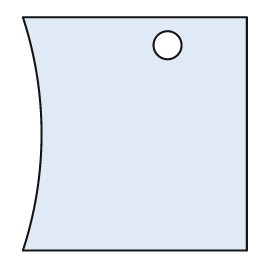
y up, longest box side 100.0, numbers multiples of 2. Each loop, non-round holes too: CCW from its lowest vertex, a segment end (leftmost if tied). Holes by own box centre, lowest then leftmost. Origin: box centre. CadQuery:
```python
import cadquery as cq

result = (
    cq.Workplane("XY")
    .moveTo(-48.0, -50.0)
    .lineTo(48.0, -50.0)
    .lineTo(48.0, 50.0)
    .lineTo(-48.0, 50.0)
    .threePointArc((-40.0, 0.0), (-48.0, -50.0))
    .close()
    .moveTo(14.0, 38.0)
    .circle(6.0)
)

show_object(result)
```